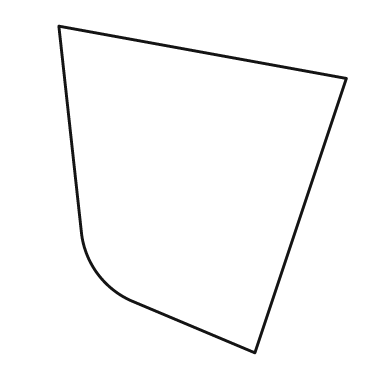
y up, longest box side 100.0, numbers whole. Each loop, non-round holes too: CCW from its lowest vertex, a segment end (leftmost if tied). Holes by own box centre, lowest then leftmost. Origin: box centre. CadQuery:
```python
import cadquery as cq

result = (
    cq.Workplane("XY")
    .moveTo(16.0, -50.0)
    .lineTo(44.0, 34.0)
    .lineTo(-44.0, 50.0)
    .lineTo(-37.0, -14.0)
    .threePointArc((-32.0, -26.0), (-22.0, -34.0))
    .close()
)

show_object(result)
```